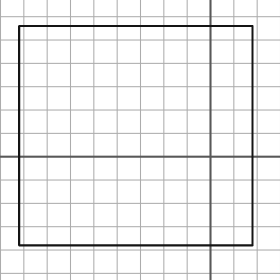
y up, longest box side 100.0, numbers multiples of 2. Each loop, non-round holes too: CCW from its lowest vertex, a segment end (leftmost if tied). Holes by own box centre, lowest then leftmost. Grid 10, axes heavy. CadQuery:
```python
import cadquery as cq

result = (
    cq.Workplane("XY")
    .moveTo(-82.0, -38.0)
    .lineTo(18.0, -38.0)
    .lineTo(18.0, 56.0)
    .lineTo(-82.0, 56.0)
    .close()
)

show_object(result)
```